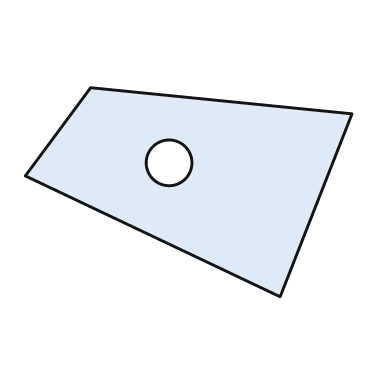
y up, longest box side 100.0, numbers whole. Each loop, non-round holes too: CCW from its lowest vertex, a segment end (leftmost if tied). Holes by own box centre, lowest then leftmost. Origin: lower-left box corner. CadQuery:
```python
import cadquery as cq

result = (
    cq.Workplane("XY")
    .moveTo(78.0, 0.0)
    .lineTo(100.0, 56.0)
    .lineTo(20.0, 64.0)
    .lineTo(0.0, 37.0)
    .close()
    .moveTo(44.0, 41.0)
    .circle(7.0)
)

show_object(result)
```